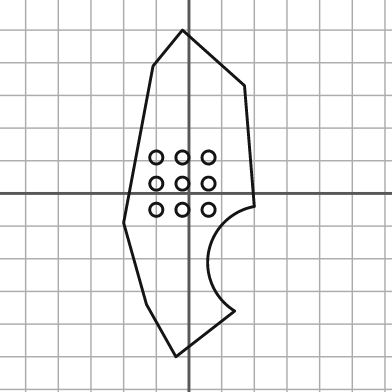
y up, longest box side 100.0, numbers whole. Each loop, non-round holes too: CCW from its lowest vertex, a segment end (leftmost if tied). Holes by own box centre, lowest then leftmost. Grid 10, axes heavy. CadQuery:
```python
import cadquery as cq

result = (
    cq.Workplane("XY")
    .moveTo(-4.0, -50.0)
    .lineTo(14.0, -36.0)
    .threePointArc((6.0, -18.0), (20.0, -4.0))
    .lineTo(17.0, 33.0)
    .lineTo(-2.0, 50.0)
    .lineTo(-11.0, 39.0)
    .lineTo(-20.0, -9.0)
    .lineTo(-13.0, -34.0)
    .close()
    .moveTo(-10.0, -5.0)
    .circle(2.0)
    .moveTo(-2.0, -5.0)
    .circle(2.0)
    .moveTo(6.0, -5.0)
    .circle(2.0)
    .moveTo(-10.0, 3.0)
    .circle(2.0)
    .moveTo(-2.0, 3.0)
    .circle(2.0)
    .moveTo(6.0, 3.0)
    .circle(2.0)
    .moveTo(-10.0, 11.0)
    .circle(2.0)
    .moveTo(-2.0, 11.0)
    .circle(2.0)
    .moveTo(6.0, 11.0)
    .circle(2.0)
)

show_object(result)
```